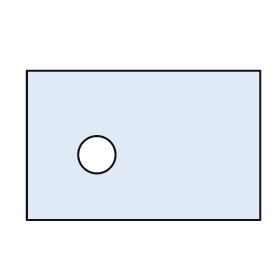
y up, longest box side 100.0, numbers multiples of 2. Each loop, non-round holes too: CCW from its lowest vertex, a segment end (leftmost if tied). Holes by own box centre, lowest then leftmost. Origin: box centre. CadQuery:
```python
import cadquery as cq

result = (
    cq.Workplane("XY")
    .moveTo(-50.0, -32.0)
    .lineTo(50.0, -32.0)
    .lineTo(50.0, 32.0)
    .lineTo(-50.0, 32.0)
    .close()
    .moveTo(-20.0, -4.0)
    .circle(8.0)
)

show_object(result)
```